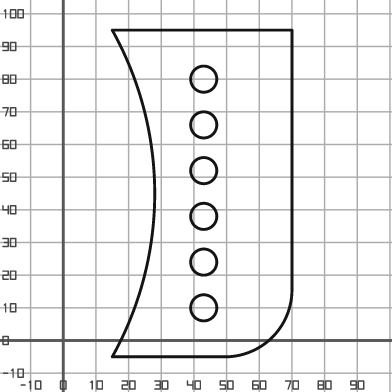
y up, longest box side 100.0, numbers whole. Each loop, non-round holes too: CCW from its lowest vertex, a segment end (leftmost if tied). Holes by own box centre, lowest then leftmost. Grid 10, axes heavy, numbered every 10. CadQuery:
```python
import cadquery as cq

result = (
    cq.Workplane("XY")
    .moveTo(15.0, -5.0)
    .lineTo(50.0, -5.0)
    .threePointArc((64.0, 1.0), (70.0, 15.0))
    .lineTo(70.0, 95.0)
    .lineTo(15.0, 95.0)
    .threePointArc((28.0, 45.0), (15.0, -5.0))
    .close()
    .moveTo(43.0, 10.0)
    .circle(4.0)
    .moveTo(43.0, 24.0)
    .circle(4.0)
    .moveTo(43.0, 38.0)
    .circle(4.0)
    .moveTo(43.0, 52.0)
    .circle(4.0)
    .moveTo(43.0, 66.0)
    .circle(4.0)
    .moveTo(43.0, 80.0)
    .circle(4.0)
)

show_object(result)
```